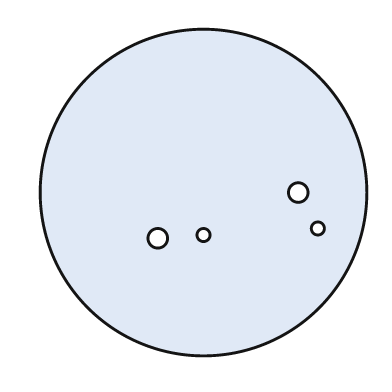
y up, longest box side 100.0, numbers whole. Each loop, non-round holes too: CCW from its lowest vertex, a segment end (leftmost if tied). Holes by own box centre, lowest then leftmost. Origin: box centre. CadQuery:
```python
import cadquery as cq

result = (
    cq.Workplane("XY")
    .moveTo(0.0, 0.0)
    .circle(50.0)
    .moveTo(-14.0, -14.0)
    .circle(3.0)
    .moveTo(0.0, -13.0)
    .circle(2.0)
    .moveTo(35.0, -11.0)
    .circle(2.0)
    .moveTo(29.0, 0.0)
    .circle(3.0)
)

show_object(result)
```